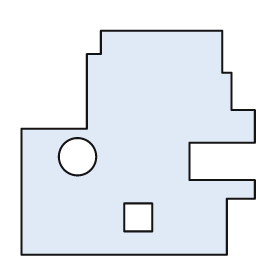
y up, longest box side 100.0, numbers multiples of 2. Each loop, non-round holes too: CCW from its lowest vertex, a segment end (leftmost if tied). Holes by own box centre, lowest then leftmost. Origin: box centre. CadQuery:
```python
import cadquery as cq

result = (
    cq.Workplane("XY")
    .moveTo(-50.0, -48.0)
    .lineTo(38.0, -48.0)
    .lineTo(38.0, -24.0)
    .lineTo(50.0, -24.0)
    .lineTo(50.0, -16.0)
    .lineTo(22.0, -16.0)
    .lineTo(22.0, 0.0)
    .lineTo(50.0, 0.0)
    .lineTo(50.0, 14.0)
    .lineTo(40.0, 14.0)
    .lineTo(40.0, 30.0)
    .lineTo(36.0, 30.0)
    .lineTo(36.0, 48.0)
    .lineTo(-16.0, 48.0)
    .lineTo(-16.0, 38.0)
    .lineTo(-22.0, 38.0)
    .lineTo(-22.0, 6.0)
    .lineTo(-50.0, 6.0)
    .close()
    .moveTo(-6.0, -38.0)
    .lineTo(6.0, -38.0)
    .lineTo(6.0, -26.0)
    .lineTo(-6.0, -26.0)
    .close()
    .moveTo(-26.0, -6.0)
    .circle(8.0)
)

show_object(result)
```